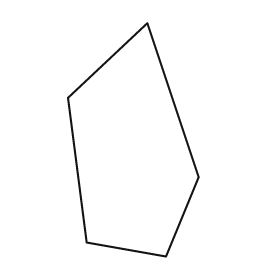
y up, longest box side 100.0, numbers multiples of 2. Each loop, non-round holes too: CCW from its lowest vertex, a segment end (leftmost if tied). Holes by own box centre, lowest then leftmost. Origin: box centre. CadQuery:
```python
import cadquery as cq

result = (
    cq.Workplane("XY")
    .moveTo(14.0, -50.0)
    .lineTo(28.0, -16.0)
    .lineTo(6.0, 50.0)
    .lineTo(-28.0, 18.0)
    .lineTo(-20.0, -44.0)
    .close()
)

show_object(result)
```